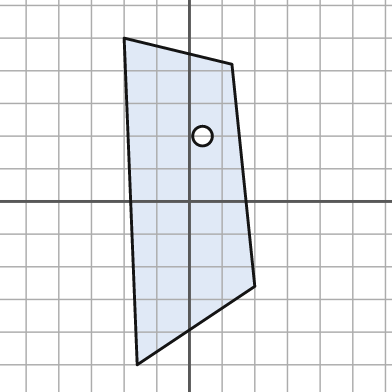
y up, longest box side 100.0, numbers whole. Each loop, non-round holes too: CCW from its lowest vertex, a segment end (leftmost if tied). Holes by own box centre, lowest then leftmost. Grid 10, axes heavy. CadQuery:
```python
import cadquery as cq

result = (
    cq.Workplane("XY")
    .moveTo(-16.0, -50.0)
    .lineTo(20.0, -26.0)
    .lineTo(13.0, 42.0)
    .lineTo(-20.0, 50.0)
    .close()
    .moveTo(4.0, 20.0)
    .circle(3.0)
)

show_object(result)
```